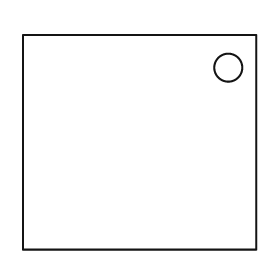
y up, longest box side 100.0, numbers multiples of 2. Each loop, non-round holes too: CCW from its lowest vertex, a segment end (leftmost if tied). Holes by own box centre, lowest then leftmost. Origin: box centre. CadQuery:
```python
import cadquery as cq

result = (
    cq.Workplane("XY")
    .moveTo(-50.0, -46.0)
    .lineTo(50.0, -46.0)
    .lineTo(50.0, 46.0)
    .lineTo(-50.0, 46.0)
    .close()
    .moveTo(38.0, 32.0)
    .circle(6.0)
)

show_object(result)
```